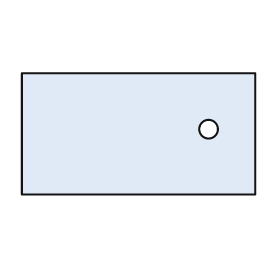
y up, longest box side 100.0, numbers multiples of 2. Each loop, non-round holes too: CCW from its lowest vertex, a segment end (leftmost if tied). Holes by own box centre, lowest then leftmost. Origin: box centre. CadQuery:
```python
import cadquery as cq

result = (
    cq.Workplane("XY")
    .moveTo(-50.0, -26.0)
    .lineTo(50.0, -26.0)
    .lineTo(50.0, 26.0)
    .lineTo(-50.0, 26.0)
    .close()
    .moveTo(30.0, 2.0)
    .circle(4.0)
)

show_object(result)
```